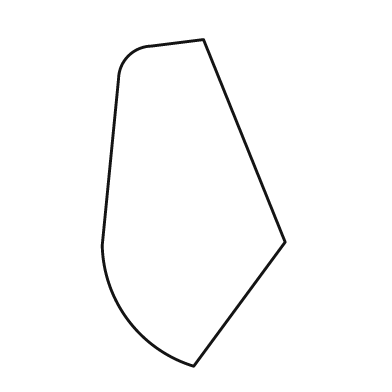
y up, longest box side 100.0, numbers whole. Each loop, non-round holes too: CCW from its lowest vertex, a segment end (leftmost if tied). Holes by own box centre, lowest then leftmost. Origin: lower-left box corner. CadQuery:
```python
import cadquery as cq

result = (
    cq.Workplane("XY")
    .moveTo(28.0, 0.0)
    .lineTo(56.0, 38.0)
    .lineTo(31.0, 100.0)
    .lineTo(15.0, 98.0)
    .threePointArc((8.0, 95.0), (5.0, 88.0))
    .lineTo(0.0, 37.0)
    .threePointArc((8.0, 14.0), (28.0, 0.0))
    .close()
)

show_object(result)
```